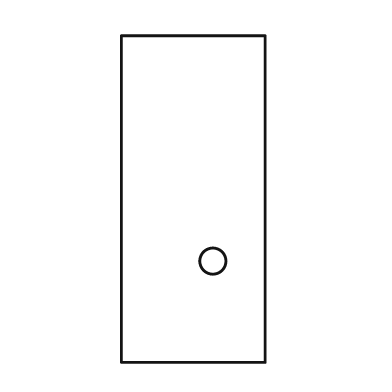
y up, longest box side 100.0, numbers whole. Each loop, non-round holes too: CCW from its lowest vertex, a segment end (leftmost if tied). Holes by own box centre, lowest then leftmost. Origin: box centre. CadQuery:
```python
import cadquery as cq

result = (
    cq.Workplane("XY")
    .moveTo(-22.0, -50.0)
    .lineTo(22.0, -50.0)
    .lineTo(22.0, 50.0)
    .lineTo(-22.0, 50.0)
    .close()
    .moveTo(6.0, -19.0)
    .circle(4.0)
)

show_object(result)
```